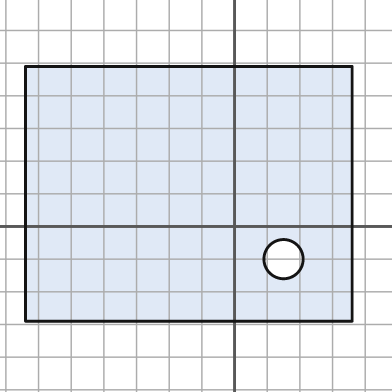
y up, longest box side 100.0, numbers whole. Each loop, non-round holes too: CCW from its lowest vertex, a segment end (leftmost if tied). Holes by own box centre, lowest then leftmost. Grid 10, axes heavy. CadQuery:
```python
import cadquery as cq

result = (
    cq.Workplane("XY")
    .moveTo(-64.0, -29.0)
    .lineTo(36.0, -29.0)
    .lineTo(36.0, 49.0)
    .lineTo(-64.0, 49.0)
    .close()
    .moveTo(15.0, -10.0)
    .circle(6.0)
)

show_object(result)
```